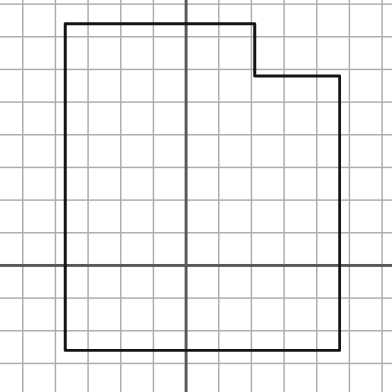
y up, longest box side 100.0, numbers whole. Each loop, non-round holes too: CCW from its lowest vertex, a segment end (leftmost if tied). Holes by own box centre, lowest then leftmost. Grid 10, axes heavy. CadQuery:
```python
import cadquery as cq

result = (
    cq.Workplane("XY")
    .moveTo(-37.0, -26.0)
    .lineTo(47.0, -26.0)
    .lineTo(47.0, 58.0)
    .lineTo(21.0, 58.0)
    .lineTo(21.0, 74.0)
    .lineTo(-37.0, 74.0)
    .close()
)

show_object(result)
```